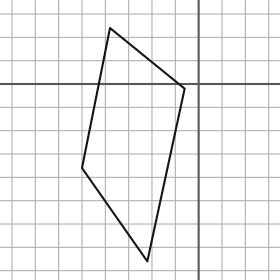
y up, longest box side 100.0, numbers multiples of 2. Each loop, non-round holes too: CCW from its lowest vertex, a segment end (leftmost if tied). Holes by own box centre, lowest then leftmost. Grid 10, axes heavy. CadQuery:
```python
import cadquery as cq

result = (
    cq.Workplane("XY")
    .moveTo(-22.0, -76.0)
    .lineTo(-6.0, -2.0)
    .lineTo(-38.0, 24.0)
    .lineTo(-50.0, -36.0)
    .close()
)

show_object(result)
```